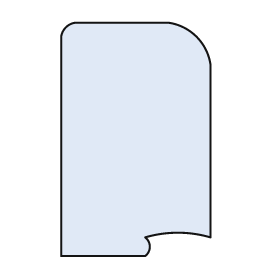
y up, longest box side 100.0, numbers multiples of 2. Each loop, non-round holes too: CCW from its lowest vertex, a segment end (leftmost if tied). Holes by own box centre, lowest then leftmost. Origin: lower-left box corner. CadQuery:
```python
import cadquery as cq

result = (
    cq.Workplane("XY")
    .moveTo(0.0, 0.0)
    .lineTo(36.0, 0.0)
    .threePointArc((38.0, 4.0), (36.0, 8.0))
    .threePointArc((50.0, 10.0), (64.0, 8.0))
    .lineTo(64.0, 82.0)
    .threePointArc((58.0, 94.0), (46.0, 100.0))
    .lineTo(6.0, 100.0)
    .threePointArc((2.0, 98.0), (0.0, 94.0))
    .close()
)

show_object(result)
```